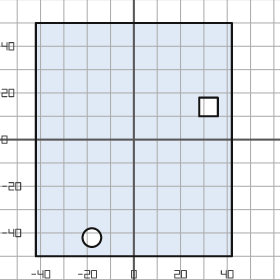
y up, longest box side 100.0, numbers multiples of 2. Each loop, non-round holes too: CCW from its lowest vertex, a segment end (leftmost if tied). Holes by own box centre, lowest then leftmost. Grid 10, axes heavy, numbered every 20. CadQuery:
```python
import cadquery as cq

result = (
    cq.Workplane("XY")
    .moveTo(-42.0, -50.0)
    .lineTo(42.0, -50.0)
    .lineTo(42.0, 50.0)
    .lineTo(-42.0, 50.0)
    .close()
    .moveTo(-18.0, -42.0)
    .circle(4.0)
    .moveTo(28.0, 10.0)
    .lineTo(36.0, 10.0)
    .lineTo(36.0, 18.0)
    .lineTo(28.0, 18.0)
    .close()
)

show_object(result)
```